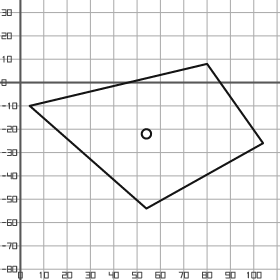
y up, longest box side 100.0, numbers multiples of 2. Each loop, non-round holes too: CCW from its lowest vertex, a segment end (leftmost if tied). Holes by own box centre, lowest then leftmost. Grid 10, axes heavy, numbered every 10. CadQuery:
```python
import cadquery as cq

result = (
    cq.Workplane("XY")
    .moveTo(54.0, -54.0)
    .lineTo(104.0, -26.0)
    .lineTo(80.0, 8.0)
    .lineTo(4.0, -10.0)
    .close()
    .moveTo(54.0, -22.0)
    .circle(2.0)
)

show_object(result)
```